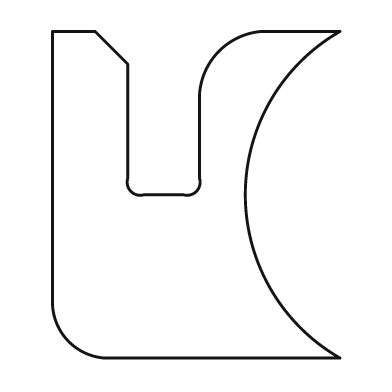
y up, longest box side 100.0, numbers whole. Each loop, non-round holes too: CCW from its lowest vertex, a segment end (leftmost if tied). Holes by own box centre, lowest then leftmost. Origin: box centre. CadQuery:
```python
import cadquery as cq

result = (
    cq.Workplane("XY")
    .moveTo(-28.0, -50.0)
    .lineTo(44.0, -50.0)
    .threePointArc((15.0, 0.0), (44.0, 50.0))
    .lineTo(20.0, 50.0)
    .threePointArc((7.0, 44.0), (1.0, 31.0))
    .lineTo(1.0, 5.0)
    .threePointArc((0.0, 1.0), (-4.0, 0.0))
    .lineTo(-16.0, 0.0)
    .threePointArc((-20.0, 1.0), (-21.0, 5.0))
    .lineTo(-21.0, 40.0)
    .lineTo(-31.0, 50.0)
    .lineTo(-44.0, 50.0)
    .lineTo(-44.0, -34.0)
    .threePointArc((-39.0, -45.0), (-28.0, -50.0))
    .close()
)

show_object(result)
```